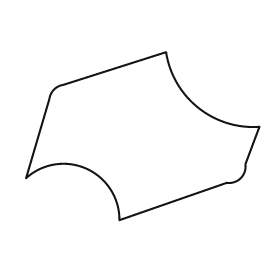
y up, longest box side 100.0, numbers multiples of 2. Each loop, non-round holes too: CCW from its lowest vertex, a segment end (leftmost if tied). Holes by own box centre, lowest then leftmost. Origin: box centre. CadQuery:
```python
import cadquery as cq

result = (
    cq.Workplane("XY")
    .moveTo(-10.0, -36.0)
    .lineTo(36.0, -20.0)
    .threePointArc((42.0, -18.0), (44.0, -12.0))
    .lineTo(50.0, 4.0)
    .threePointArc((24.0, 12.0), (10.0, 36.0))
    .lineTo(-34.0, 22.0)
    .threePointArc((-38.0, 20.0), (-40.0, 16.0))
    .lineTo(-50.0, -18.0)
    .threePointArc((-24.0, -14.0), (-10.0, -36.0))
    .close()
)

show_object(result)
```